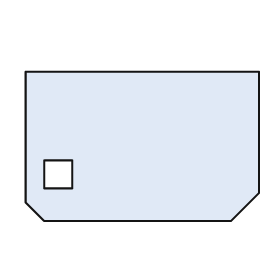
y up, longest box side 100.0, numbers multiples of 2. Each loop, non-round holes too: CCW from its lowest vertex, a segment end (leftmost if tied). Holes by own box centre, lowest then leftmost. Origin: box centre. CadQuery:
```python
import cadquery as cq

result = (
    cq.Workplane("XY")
    .moveTo(-42.0, -32.0)
    .lineTo(38.0, -32.0)
    .lineTo(50.0, -20.0)
    .lineTo(50.0, 32.0)
    .lineTo(-50.0, 32.0)
    .lineTo(-50.0, -24.0)
    .close()
    .moveTo(-42.0, -18.0)
    .lineTo(-30.0, -18.0)
    .lineTo(-30.0, -6.0)
    .lineTo(-42.0, -6.0)
    .close()
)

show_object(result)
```